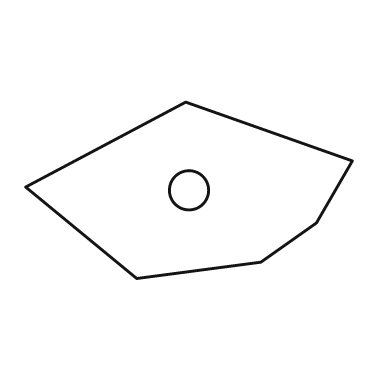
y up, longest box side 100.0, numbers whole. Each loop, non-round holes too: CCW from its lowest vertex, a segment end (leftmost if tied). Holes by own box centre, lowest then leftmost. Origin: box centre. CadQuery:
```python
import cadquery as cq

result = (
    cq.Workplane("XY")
    .moveTo(-16.0, -27.0)
    .lineTo(22.0, -22.0)
    .lineTo(39.0, -10.0)
    .lineTo(50.0, 9.0)
    .lineTo(-1.0, 27.0)
    .lineTo(-50.0, 1.0)
    .close()
    .moveTo(0.0, 0.0)
    .circle(6.0)
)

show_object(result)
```